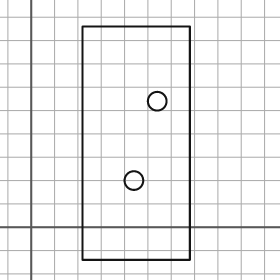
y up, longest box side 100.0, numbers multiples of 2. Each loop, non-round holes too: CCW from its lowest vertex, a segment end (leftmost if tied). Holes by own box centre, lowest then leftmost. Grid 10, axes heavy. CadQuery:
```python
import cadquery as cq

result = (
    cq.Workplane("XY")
    .moveTo(22.0, -14.0)
    .lineTo(68.0, -14.0)
    .lineTo(68.0, 86.0)
    .lineTo(22.0, 86.0)
    .close()
    .moveTo(44.0, 20.0)
    .circle(4.0)
    .moveTo(54.0, 54.0)
    .circle(4.0)
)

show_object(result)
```